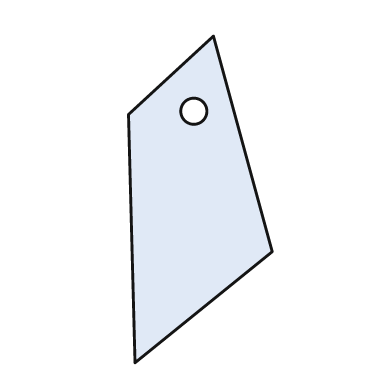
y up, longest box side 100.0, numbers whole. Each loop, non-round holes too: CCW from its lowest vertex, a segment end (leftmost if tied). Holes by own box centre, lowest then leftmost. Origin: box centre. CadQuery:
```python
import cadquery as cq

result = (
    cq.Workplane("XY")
    .moveTo(-20.0, -50.0)
    .lineTo(22.0, -16.0)
    .lineTo(4.0, 50.0)
    .lineTo(-22.0, 26.0)
    .close()
    .moveTo(-2.0, 27.0)
    .circle(4.0)
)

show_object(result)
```